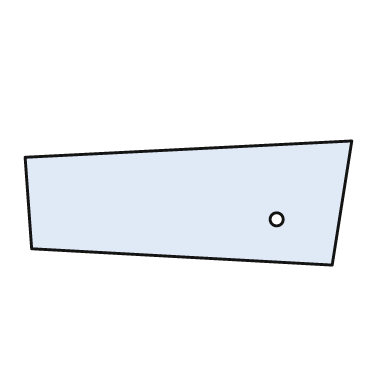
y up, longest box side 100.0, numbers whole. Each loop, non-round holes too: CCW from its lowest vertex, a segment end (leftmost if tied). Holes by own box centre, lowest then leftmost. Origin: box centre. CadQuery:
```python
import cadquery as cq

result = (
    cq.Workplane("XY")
    .moveTo(44.0, -19.0)
    .lineTo(50.0, 19.0)
    .lineTo(-50.0, 14.0)
    .lineTo(-48.0, -14.0)
    .close()
    .moveTo(27.0, -5.0)
    .circle(2.0)
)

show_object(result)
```